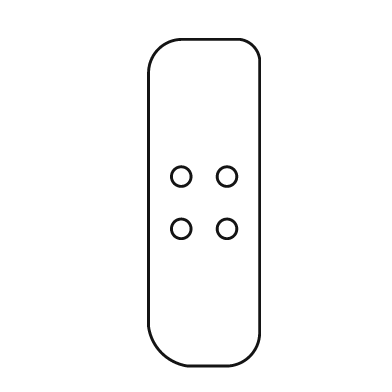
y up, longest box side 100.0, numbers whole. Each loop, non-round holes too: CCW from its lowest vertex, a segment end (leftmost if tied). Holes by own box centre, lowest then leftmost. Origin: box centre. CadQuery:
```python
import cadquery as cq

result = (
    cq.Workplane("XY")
    .moveTo(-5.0, -50.0)
    .lineTo(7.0, -50.0)
    .threePointArc((14.0, -47.0), (17.0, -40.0))
    .lineTo(17.0, 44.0)
    .threePointArc((15.0, 48.0), (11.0, 50.0))
    .lineTo(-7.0, 50.0)
    .threePointArc((-14.0, 47.0), (-17.0, 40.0))
    .lineTo(-17.0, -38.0)
    .threePointArc((-13.0, -46.0), (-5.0, -50.0))
    .close()
    .moveTo(-7.0, -8.0)
    .circle(3.0)
    .moveTo(7.0, -8.0)
    .circle(3.0)
    .moveTo(-7.0, 8.0)
    .circle(3.0)
    .moveTo(7.0, 8.0)
    .circle(3.0)
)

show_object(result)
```